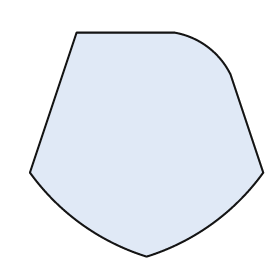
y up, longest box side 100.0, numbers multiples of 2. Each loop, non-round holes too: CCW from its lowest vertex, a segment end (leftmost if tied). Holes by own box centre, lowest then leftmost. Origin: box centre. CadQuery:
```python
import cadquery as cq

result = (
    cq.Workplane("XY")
    .moveTo(0.0, -48.0)
    .threePointArc((28.0, -34.0), (50.0, -12.0))
    .lineTo(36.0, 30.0)
    .threePointArc((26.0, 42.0), (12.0, 48.0))
    .lineTo(-30.0, 48.0)
    .lineTo(-50.0, -12.0)
    .threePointArc((-28.0, -34.0), (0.0, -48.0))
    .close()
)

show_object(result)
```